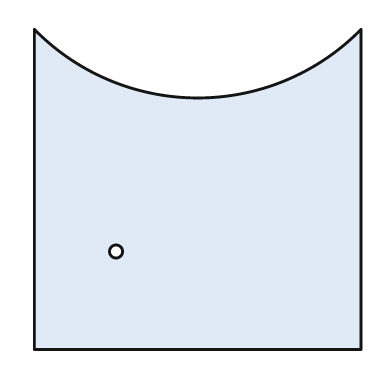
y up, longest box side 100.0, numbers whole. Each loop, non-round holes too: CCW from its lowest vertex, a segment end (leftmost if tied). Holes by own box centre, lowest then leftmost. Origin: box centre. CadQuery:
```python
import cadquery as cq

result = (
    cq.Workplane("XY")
    .moveTo(-50.0, -49.0)
    .lineTo(50.0, -49.0)
    .lineTo(50.0, 49.0)
    .threePointArc((0.0, 28.0), (-50.0, 49.0))
    .close()
    .moveTo(-25.0, -19.0)
    .circle(2.0)
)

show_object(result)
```